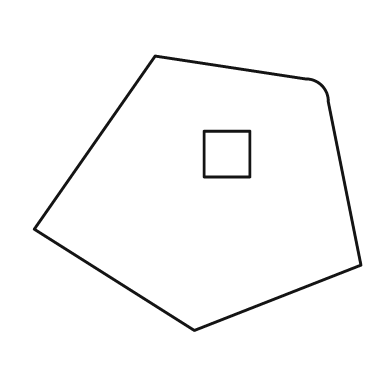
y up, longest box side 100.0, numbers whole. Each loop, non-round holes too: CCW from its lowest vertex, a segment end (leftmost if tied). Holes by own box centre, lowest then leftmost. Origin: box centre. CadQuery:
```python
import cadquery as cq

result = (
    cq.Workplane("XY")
    .moveTo(-1.0, -42.0)
    .lineTo(50.0, -22.0)
    .lineTo(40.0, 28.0)
    .threePointArc((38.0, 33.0), (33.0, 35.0))
    .lineTo(-13.0, 42.0)
    .lineTo(-50.0, -11.0)
    .close()
    .moveTo(2.0, 5.0)
    .lineTo(16.0, 5.0)
    .lineTo(16.0, 19.0)
    .lineTo(2.0, 19.0)
    .close()
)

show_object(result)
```